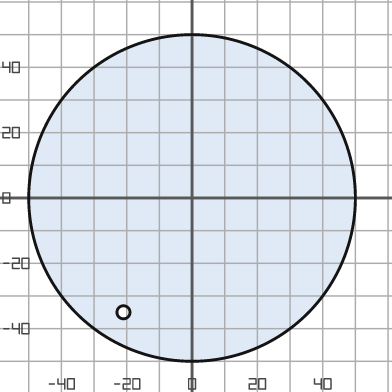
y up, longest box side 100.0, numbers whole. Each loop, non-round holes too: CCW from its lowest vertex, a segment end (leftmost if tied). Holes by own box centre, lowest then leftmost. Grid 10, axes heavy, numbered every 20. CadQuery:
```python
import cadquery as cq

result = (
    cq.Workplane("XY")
    .moveTo(0.0, 0.0)
    .circle(50.0)
    .moveTo(-21.0, -35.0)
    .circle(2.0)
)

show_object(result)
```